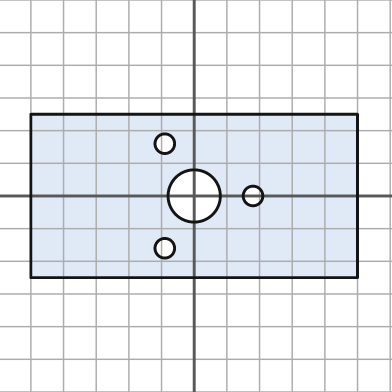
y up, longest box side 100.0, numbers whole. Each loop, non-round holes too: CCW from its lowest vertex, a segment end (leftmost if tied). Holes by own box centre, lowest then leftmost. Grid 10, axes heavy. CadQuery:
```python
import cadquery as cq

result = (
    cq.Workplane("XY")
    .moveTo(-50.0, -25.0)
    .lineTo(50.0, -25.0)
    .lineTo(50.0, 25.0)
    .lineTo(-50.0, 25.0)
    .close()
    .moveTo(-9.0, -16.0)
    .circle(3.0)
    .moveTo(0.0, 0.0)
    .circle(8.0)
    .moveTo(18.0, 0.0)
    .circle(3.0)
    .moveTo(-9.0, 16.0)
    .circle(3.0)
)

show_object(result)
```